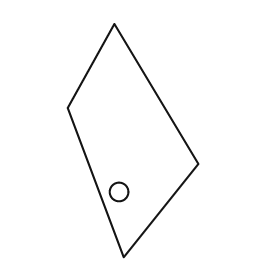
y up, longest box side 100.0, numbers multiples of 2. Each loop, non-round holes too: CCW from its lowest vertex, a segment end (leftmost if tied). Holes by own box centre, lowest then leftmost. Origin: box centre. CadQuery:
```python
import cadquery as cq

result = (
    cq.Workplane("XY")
    .moveTo(-4.0, -50.0)
    .lineTo(28.0, -10.0)
    .lineTo(-8.0, 50.0)
    .lineTo(-28.0, 14.0)
    .close()
    .moveTo(-6.0, -22.0)
    .circle(4.0)
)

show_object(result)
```